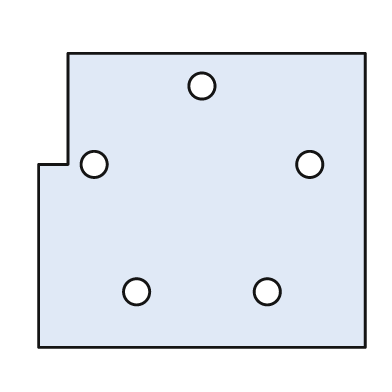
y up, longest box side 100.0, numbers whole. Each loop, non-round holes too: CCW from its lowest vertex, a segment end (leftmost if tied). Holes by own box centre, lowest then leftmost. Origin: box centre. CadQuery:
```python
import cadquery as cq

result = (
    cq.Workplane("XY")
    .moveTo(-50.0, -45.0)
    .lineTo(50.0, -45.0)
    .lineTo(50.0, 45.0)
    .lineTo(-41.0, 45.0)
    .lineTo(-41.0, 11.0)
    .lineTo(-50.0, 11.0)
    .close()
    .moveTo(-20.0, -28.0)
    .circle(4.0)
    .moveTo(20.0, -28.0)
    .circle(4.0)
    .moveTo(-33.0, 11.0)
    .circle(4.0)
    .moveTo(33.0, 11.0)
    .circle(4.0)
    .moveTo(0.0, 35.0)
    .circle(4.0)
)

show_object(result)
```